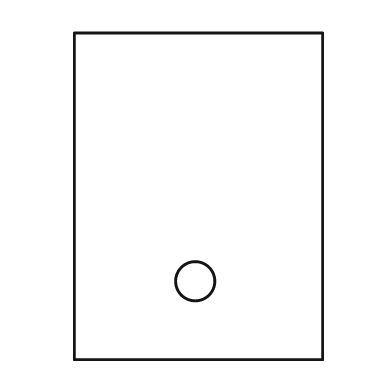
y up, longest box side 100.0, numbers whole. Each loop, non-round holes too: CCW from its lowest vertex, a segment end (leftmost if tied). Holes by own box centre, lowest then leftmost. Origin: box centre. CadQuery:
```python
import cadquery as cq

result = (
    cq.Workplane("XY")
    .moveTo(-38.0, -50.0)
    .lineTo(38.0, -50.0)
    .lineTo(38.0, 50.0)
    .lineTo(-38.0, 50.0)
    .close()
    .moveTo(-1.0, -26.0)
    .circle(6.0)
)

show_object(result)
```